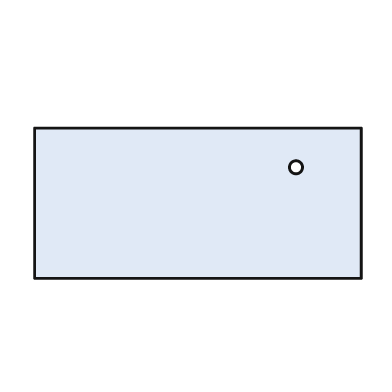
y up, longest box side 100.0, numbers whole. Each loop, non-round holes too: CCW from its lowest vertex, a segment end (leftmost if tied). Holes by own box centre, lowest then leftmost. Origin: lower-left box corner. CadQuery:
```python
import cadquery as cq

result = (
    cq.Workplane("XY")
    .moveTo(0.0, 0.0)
    .lineTo(100.0, 0.0)
    .lineTo(100.0, 46.0)
    .lineTo(0.0, 46.0)
    .close()
    .moveTo(80.0, 34.0)
    .circle(2.0)
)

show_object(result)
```